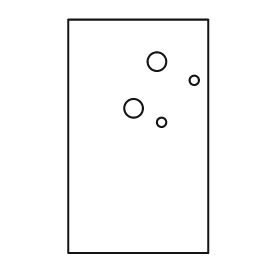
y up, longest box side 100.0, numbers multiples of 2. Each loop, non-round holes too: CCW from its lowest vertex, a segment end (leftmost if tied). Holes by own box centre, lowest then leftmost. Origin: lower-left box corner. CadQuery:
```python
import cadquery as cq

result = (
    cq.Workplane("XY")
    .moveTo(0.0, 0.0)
    .lineTo(60.0, 0.0)
    .lineTo(60.0, 100.0)
    .lineTo(0.0, 100.0)
    .close()
    .moveTo(40.0, 56.0)
    .circle(2.0)
    .moveTo(28.0, 62.0)
    .circle(4.0)
    .moveTo(54.0, 74.0)
    .circle(2.0)
    .moveTo(38.0, 82.0)
    .circle(4.0)
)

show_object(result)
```